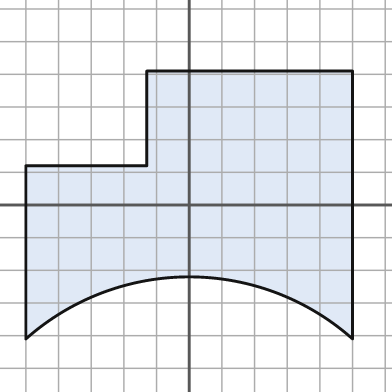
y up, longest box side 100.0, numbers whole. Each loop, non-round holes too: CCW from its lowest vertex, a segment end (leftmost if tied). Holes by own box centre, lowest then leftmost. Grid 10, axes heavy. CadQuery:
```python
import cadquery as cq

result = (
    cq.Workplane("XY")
    .moveTo(-50.0, -41.0)
    .threePointArc((0.0, -22.0), (50.0, -41.0))
    .lineTo(50.0, 41.0)
    .lineTo(-13.0, 41.0)
    .lineTo(-13.0, 12.0)
    .lineTo(-50.0, 12.0)
    .close()
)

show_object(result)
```